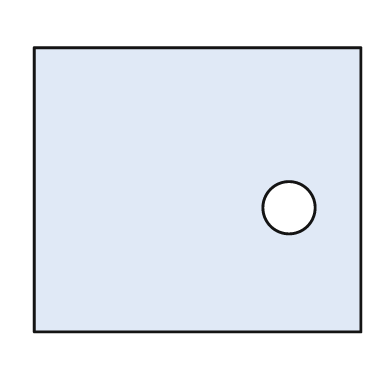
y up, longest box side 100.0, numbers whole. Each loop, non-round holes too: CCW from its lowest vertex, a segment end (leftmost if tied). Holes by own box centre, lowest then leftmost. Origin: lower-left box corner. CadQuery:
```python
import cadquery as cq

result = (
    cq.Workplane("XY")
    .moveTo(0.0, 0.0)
    .lineTo(100.0, 0.0)
    .lineTo(100.0, 87.0)
    .lineTo(0.0, 87.0)
    .close()
    .moveTo(78.0, 38.0)
    .circle(8.0)
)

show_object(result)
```